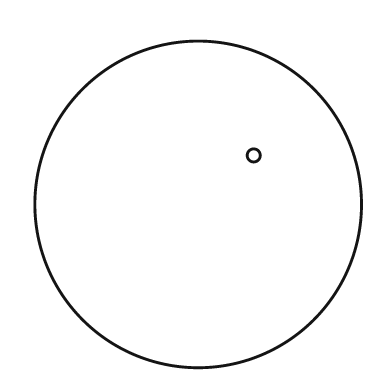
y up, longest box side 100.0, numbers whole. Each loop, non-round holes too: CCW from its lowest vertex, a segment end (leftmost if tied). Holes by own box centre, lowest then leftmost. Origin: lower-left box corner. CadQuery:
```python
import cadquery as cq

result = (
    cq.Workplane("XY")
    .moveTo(50.0, 50.0)
    .circle(50.0)
    .moveTo(67.0, 65.0)
    .circle(2.0)
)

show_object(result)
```